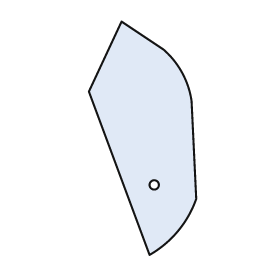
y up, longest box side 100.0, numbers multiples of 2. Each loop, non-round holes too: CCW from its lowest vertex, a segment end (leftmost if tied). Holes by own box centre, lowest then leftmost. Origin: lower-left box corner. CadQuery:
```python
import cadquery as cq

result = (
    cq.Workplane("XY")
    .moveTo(26.0, 0.0)
    .threePointArc((38.0, 10.0), (46.0, 24.0))
    .lineTo(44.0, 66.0)
    .threePointArc((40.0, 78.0), (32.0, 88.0))
    .lineTo(14.0, 100.0)
    .lineTo(0.0, 70.0)
    .close()
    .moveTo(28.0, 30.0)
    .circle(2.0)
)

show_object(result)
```